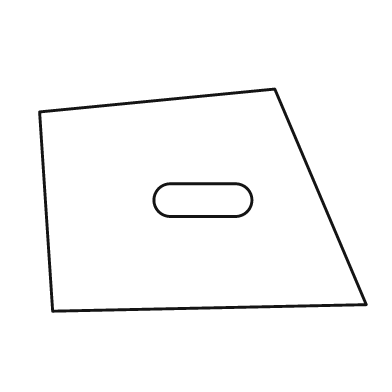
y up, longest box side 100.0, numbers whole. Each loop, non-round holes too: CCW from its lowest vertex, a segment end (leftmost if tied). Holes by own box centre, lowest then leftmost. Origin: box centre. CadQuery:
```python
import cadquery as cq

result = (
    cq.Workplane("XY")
    .moveTo(-46.0, -34.0)
    .lineTo(50.0, -32.0)
    .lineTo(22.0, 34.0)
    .lineTo(-50.0, 27.0)
    .close()
    .moveTo(-10.0, -5.0)
    .lineTo(10.0, -5.0)
    .threePointArc((15.0, 0.0), (10.0, 5.0))
    .lineTo(-10.0, 5.0)
    .threePointArc((-15.0, 0.0), (-10.0, -5.0))
    .close()
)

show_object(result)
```